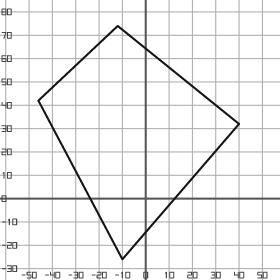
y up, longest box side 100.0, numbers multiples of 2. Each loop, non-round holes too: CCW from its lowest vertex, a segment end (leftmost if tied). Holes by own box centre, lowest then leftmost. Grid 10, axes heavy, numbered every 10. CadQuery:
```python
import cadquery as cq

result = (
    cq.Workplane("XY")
    .moveTo(-10.0, -26.0)
    .lineTo(40.0, 32.0)
    .lineTo(-12.0, 74.0)
    .lineTo(-46.0, 42.0)
    .close()
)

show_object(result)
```